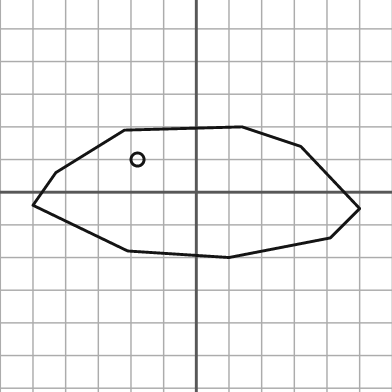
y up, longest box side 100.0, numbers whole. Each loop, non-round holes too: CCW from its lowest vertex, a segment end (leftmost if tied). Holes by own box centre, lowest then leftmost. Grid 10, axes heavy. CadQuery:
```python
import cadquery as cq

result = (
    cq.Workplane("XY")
    .moveTo(10.0, -20.0)
    .lineTo(41.0, -14.0)
    .lineTo(50.0, -5.0)
    .lineTo(32.0, 14.0)
    .lineTo(14.0, 20.0)
    .lineTo(-22.0, 19.0)
    .lineTo(-43.0, 6.0)
    .lineTo(-50.0, -4.0)
    .lineTo(-21.0, -18.0)
    .close()
    .moveTo(-18.0, 10.0)
    .circle(2.0)
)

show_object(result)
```